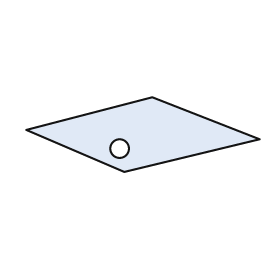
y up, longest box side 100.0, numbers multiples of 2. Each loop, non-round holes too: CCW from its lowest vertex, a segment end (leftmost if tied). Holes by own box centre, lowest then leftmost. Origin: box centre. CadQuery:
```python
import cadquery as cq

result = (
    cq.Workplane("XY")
    .moveTo(-8.0, -16.0)
    .lineTo(50.0, -2.0)
    .lineTo(4.0, 16.0)
    .lineTo(-50.0, 2.0)
    .close()
    .moveTo(-10.0, -6.0)
    .circle(4.0)
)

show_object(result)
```